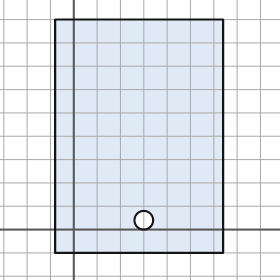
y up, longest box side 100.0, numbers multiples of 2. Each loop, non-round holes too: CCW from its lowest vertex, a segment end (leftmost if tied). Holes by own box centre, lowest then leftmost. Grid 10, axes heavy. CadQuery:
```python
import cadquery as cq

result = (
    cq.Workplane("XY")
    .moveTo(-8.0, -10.0)
    .lineTo(64.0, -10.0)
    .lineTo(64.0, 90.0)
    .lineTo(-8.0, 90.0)
    .close()
    .moveTo(30.0, 4.0)
    .circle(4.0)
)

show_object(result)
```